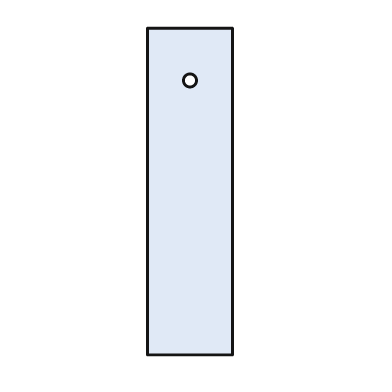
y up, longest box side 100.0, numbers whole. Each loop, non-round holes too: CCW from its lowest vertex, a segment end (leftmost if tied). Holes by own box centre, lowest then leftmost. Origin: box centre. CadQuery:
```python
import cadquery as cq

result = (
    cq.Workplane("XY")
    .moveTo(-13.0, -50.0)
    .lineTo(13.0, -50.0)
    .lineTo(13.0, 50.0)
    .lineTo(-13.0, 50.0)
    .close()
    .moveTo(0.0, 34.0)
    .circle(2.0)
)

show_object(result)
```